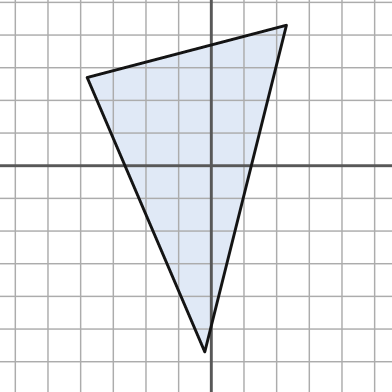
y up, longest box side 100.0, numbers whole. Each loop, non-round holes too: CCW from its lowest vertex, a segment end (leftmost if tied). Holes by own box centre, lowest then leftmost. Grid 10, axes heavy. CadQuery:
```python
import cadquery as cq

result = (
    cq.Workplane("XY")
    .moveTo(-2.0, -57.0)
    .lineTo(23.0, 43.0)
    .lineTo(-38.0, 27.0)
    .close()
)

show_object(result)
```